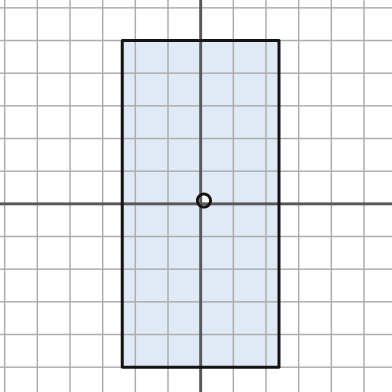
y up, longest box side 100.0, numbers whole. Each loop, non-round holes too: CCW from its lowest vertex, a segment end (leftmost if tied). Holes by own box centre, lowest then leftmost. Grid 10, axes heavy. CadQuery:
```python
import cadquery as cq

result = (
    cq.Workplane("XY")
    .moveTo(-24.0, -50.0)
    .lineTo(24.0, -50.0)
    .lineTo(24.0, 50.0)
    .lineTo(-24.0, 50.0)
    .close()
    .moveTo(1.0, 1.0)
    .circle(2.0)
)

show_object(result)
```